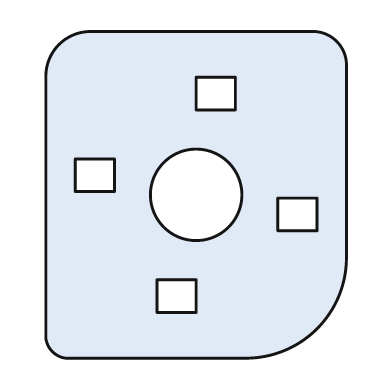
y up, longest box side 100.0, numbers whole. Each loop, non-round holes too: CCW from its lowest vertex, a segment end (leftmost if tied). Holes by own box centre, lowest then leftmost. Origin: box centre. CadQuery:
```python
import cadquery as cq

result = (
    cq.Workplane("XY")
    .moveTo(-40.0, -50.0)
    .lineTo(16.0, -50.0)
    .threePointArc((37.0, -41.0), (46.0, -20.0))
    .lineTo(46.0, 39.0)
    .threePointArc((43.0, 47.0), (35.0, 50.0))
    .lineTo(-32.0, 50.0)
    .threePointArc((-42.0, 46.0), (-46.0, 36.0))
    .lineTo(-46.0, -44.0)
    .threePointArc((-44.0, -48.0), (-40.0, -50.0))
    .close()
    .moveTo(-12.0, -36.0)
    .lineTo(0.0, -36.0)
    .lineTo(0.0, -26.0)
    .lineTo(-12.0, -26.0)
    .close()
    .moveTo(25.0, -11.0)
    .lineTo(37.0, -11.0)
    .lineTo(37.0, -1.0)
    .lineTo(25.0, -1.0)
    .close()
    .moveTo(0.0, 0.0)
    .circle(14.0)
    .moveTo(-37.0, 1.0)
    .lineTo(-25.0, 1.0)
    .lineTo(-25.0, 11.0)
    .lineTo(-37.0, 11.0)
    .close()
    .moveTo(0.0, 26.0)
    .lineTo(12.0, 26.0)
    .lineTo(12.0, 36.0)
    .lineTo(0.0, 36.0)
    .close()
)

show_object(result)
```